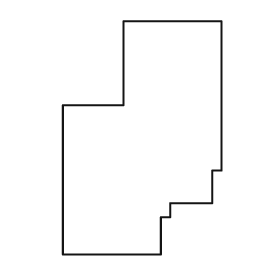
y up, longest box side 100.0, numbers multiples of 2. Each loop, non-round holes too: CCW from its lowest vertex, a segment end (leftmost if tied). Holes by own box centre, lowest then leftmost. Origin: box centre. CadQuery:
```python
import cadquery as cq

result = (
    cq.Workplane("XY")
    .moveTo(-34.0, -50.0)
    .lineTo(8.0, -50.0)
    .lineTo(8.0, -34.0)
    .lineTo(12.0, -34.0)
    .lineTo(12.0, -28.0)
    .lineTo(30.0, -28.0)
    .lineTo(30.0, -14.0)
    .lineTo(34.0, -14.0)
    .lineTo(34.0, 50.0)
    .lineTo(-8.0, 50.0)
    .lineTo(-8.0, 14.0)
    .lineTo(-34.0, 14.0)
    .close()
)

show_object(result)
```